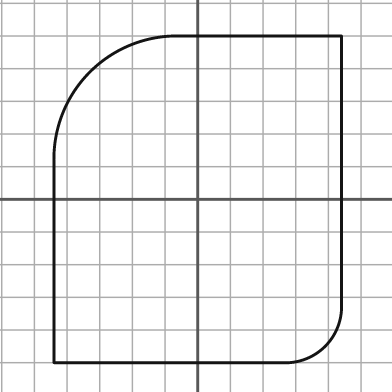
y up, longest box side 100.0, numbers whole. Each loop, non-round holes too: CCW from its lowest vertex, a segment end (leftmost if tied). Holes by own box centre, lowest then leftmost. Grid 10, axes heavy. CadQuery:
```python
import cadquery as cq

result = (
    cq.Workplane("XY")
    .moveTo(-44.0, -50.0)
    .lineTo(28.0, -50.0)
    .threePointArc((39.0, -45.0), (44.0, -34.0))
    .lineTo(44.0, 50.0)
    .lineTo(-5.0, 50.0)
    .threePointArc((-33.0, 39.0), (-44.0, 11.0))
    .close()
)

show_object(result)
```